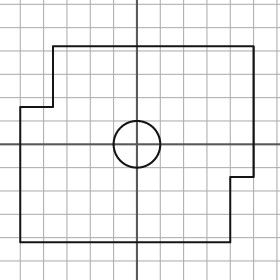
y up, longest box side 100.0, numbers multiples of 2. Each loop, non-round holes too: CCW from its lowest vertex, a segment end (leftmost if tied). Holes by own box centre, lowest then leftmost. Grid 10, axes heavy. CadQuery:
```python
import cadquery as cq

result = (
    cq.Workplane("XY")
    .moveTo(-50.0, -42.0)
    .lineTo(40.0, -42.0)
    .lineTo(40.0, -14.0)
    .lineTo(50.0, -14.0)
    .lineTo(50.0, 42.0)
    .lineTo(-36.0, 42.0)
    .lineTo(-36.0, 16.0)
    .lineTo(-50.0, 16.0)
    .close()
    .moveTo(0.0, 0.0)
    .circle(10.0)
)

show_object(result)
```